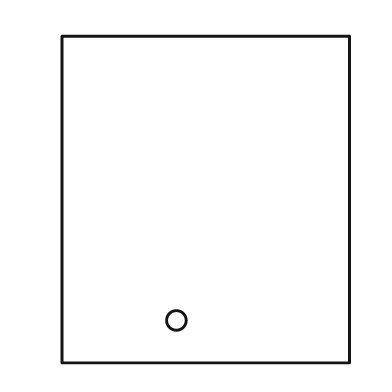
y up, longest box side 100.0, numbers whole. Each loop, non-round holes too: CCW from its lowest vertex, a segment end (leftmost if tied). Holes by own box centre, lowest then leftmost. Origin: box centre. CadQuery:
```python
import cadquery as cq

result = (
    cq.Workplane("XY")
    .moveTo(-44.0, -50.0)
    .lineTo(44.0, -50.0)
    .lineTo(44.0, 50.0)
    .lineTo(-44.0, 50.0)
    .close()
    .moveTo(-9.0, -37.0)
    .circle(3.0)
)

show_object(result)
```